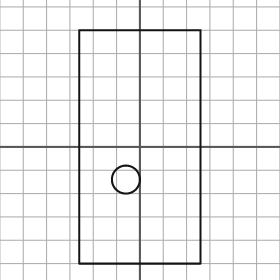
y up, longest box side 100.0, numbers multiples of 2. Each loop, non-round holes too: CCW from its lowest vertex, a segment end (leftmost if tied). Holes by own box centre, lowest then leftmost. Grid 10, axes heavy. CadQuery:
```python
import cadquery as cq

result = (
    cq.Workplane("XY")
    .moveTo(-26.0, -50.0)
    .lineTo(26.0, -50.0)
    .lineTo(26.0, 50.0)
    .lineTo(-26.0, 50.0)
    .close()
    .moveTo(-6.0, -14.0)
    .circle(6.0)
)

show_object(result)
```